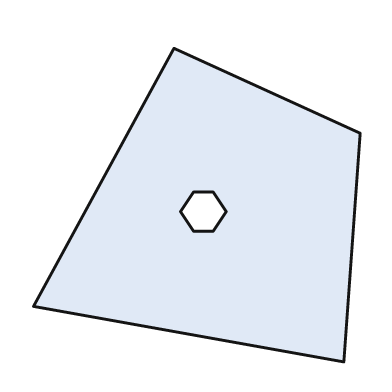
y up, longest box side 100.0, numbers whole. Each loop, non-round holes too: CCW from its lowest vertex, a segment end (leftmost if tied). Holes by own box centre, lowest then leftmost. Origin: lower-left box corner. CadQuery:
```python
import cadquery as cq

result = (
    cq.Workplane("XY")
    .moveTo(95.0, 0.0)
    .lineTo(100.0, 70.0)
    .lineTo(43.0, 96.0)
    .lineTo(0.0, 17.0)
    .close()
    .moveTo(49.0, 40.0)
    .lineTo(55.0, 40.0)
    .lineTo(59.0, 46.0)
    .lineTo(55.0, 52.0)
    .lineTo(49.0, 52.0)
    .lineTo(45.0, 46.0)
    .close()
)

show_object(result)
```